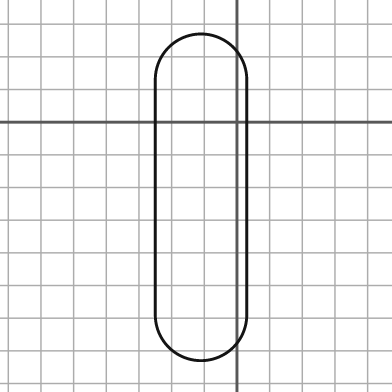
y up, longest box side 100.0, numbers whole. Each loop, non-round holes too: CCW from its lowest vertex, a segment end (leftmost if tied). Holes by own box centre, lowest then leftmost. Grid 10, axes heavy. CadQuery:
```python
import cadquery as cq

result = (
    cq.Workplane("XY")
    .moveTo(-25.0, -59.0)
    .threePointArc((-11.0, -73.0), (3.0, -59.0))
    .lineTo(3.0, 13.0)
    .threePointArc((-11.0, 27.0), (-25.0, 13.0))
    .close()
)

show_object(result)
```